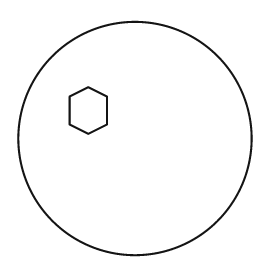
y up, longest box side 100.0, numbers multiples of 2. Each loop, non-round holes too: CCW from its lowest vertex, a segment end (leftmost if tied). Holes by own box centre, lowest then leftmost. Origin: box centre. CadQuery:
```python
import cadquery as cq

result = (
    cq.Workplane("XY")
    .moveTo(0.0, 0.0)
    .circle(50.0)
    .moveTo(-20.0, 2.0)
    .lineTo(-12.0, 6.0)
    .lineTo(-12.0, 18.0)
    .lineTo(-20.0, 22.0)
    .lineTo(-28.0, 18.0)
    .lineTo(-28.0, 6.0)
    .close()
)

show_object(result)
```